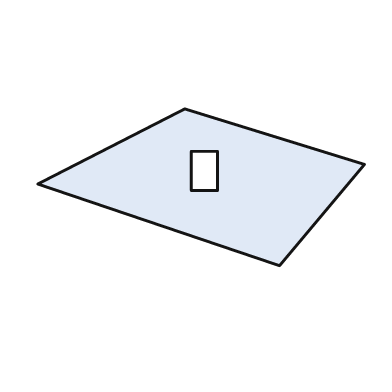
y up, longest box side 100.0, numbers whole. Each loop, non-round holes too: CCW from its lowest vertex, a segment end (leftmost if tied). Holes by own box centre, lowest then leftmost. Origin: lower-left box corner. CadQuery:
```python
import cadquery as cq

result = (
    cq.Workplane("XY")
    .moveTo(74.0, 0.0)
    .lineTo(100.0, 31.0)
    .lineTo(45.0, 48.0)
    .lineTo(0.0, 25.0)
    .close()
    .moveTo(47.0, 23.0)
    .lineTo(55.0, 23.0)
    .lineTo(55.0, 35.0)
    .lineTo(47.0, 35.0)
    .close()
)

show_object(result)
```